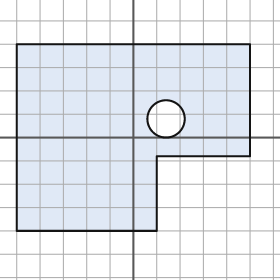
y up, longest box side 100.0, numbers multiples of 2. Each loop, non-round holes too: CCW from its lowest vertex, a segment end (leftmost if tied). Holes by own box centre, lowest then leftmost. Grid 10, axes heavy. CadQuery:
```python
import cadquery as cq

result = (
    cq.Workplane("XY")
    .moveTo(-50.0, -40.0)
    .lineTo(10.0, -40.0)
    .lineTo(10.0, -8.0)
    .lineTo(50.0, -8.0)
    .lineTo(50.0, 40.0)
    .lineTo(-50.0, 40.0)
    .close()
    .moveTo(14.0, 8.0)
    .circle(8.0)
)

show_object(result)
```